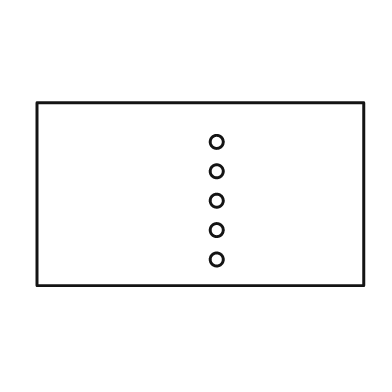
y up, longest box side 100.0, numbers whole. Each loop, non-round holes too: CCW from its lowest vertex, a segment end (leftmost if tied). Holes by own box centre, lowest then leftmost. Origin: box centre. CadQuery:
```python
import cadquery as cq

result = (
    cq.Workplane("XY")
    .moveTo(-50.0, -28.0)
    .lineTo(50.0, -28.0)
    .lineTo(50.0, 28.0)
    .lineTo(-50.0, 28.0)
    .close()
    .moveTo(5.0, -20.0)
    .circle(2.0)
    .moveTo(5.0, -11.0)
    .circle(2.0)
    .moveTo(5.0, -2.0)
    .circle(2.0)
    .moveTo(5.0, 7.0)
    .circle(2.0)
    .moveTo(5.0, 16.0)
    .circle(2.0)
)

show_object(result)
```